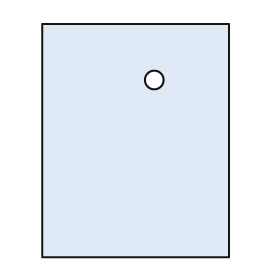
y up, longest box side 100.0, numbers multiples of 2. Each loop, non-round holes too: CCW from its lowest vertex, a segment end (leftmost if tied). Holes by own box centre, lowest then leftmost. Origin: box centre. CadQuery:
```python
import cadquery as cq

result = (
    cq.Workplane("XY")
    .moveTo(-40.0, -50.0)
    .lineTo(40.0, -50.0)
    .lineTo(40.0, 50.0)
    .lineTo(-40.0, 50.0)
    .close()
    .moveTo(8.0, 26.0)
    .circle(4.0)
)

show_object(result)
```